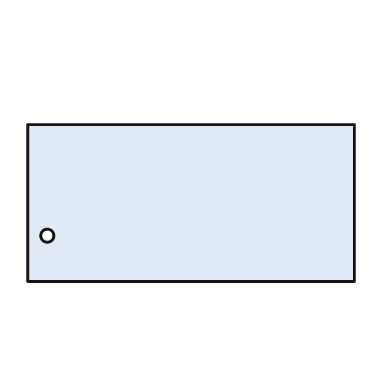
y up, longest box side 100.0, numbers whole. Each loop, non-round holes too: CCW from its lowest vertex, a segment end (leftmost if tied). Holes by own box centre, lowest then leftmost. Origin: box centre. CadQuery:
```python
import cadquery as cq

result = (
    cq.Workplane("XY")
    .moveTo(-50.0, -24.0)
    .lineTo(50.0, -24.0)
    .lineTo(50.0, 24.0)
    .lineTo(-50.0, 24.0)
    .close()
    .moveTo(-44.0, -10.0)
    .circle(2.0)
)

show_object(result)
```